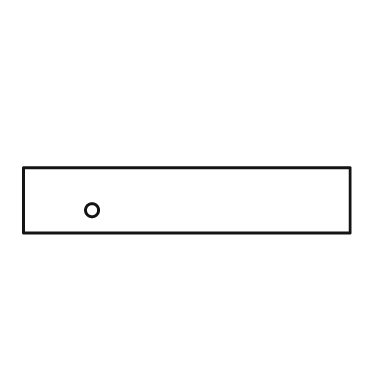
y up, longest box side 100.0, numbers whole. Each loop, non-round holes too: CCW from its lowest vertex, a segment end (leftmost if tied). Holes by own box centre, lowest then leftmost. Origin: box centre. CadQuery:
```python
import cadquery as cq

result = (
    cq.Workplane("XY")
    .moveTo(-50.0, -10.0)
    .lineTo(50.0, -10.0)
    .lineTo(50.0, 10.0)
    .lineTo(-50.0, 10.0)
    .close()
    .moveTo(-29.0, -3.0)
    .circle(2.0)
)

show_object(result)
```